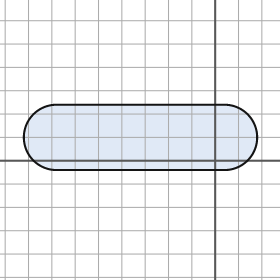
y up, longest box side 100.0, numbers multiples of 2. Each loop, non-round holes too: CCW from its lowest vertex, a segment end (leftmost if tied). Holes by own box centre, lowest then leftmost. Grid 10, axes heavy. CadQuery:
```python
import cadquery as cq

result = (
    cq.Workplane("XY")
    .moveTo(-68.0, -4.0)
    .lineTo(4.0, -4.0)
    .threePointArc((18.0, 10.0), (4.0, 24.0))
    .lineTo(-68.0, 24.0)
    .threePointArc((-82.0, 10.0), (-68.0, -4.0))
    .close()
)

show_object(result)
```